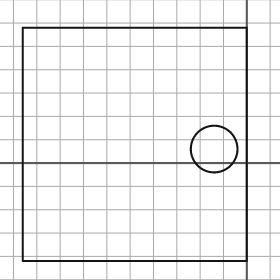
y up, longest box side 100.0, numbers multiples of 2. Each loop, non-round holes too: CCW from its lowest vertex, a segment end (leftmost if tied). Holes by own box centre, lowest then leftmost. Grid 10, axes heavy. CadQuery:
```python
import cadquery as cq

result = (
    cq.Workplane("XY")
    .moveTo(-96.0, -42.0)
    .lineTo(0.0, -42.0)
    .lineTo(0.0, 58.0)
    .lineTo(-96.0, 58.0)
    .close()
    .moveTo(-14.0, 6.0)
    .circle(10.0)
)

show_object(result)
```